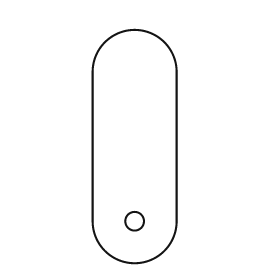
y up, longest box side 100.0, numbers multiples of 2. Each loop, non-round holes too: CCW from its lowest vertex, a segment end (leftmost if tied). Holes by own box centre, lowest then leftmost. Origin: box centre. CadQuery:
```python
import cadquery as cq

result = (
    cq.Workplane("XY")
    .moveTo(-18.0, -32.0)
    .threePointArc((0.0, -50.0), (18.0, -32.0))
    .lineTo(18.0, 32.0)
    .threePointArc((0.0, 50.0), (-18.0, 32.0))
    .close()
    .moveTo(0.0, -32.0)
    .circle(4.0)
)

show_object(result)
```